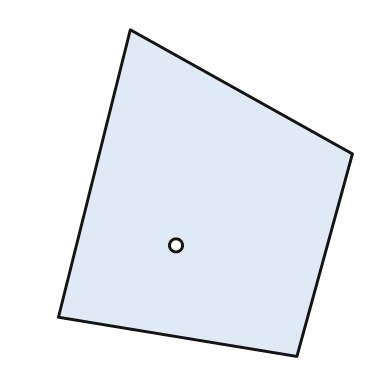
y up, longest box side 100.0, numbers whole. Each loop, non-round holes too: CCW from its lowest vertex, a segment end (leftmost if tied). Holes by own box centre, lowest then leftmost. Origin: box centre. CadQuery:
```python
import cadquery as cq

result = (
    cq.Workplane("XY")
    .moveTo(28.0, -50.0)
    .lineTo(45.0, 12.0)
    .lineTo(-23.0, 50.0)
    .lineTo(-45.0, -38.0)
    .close()
    .moveTo(-9.0, -16.0)
    .circle(2.0)
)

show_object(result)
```